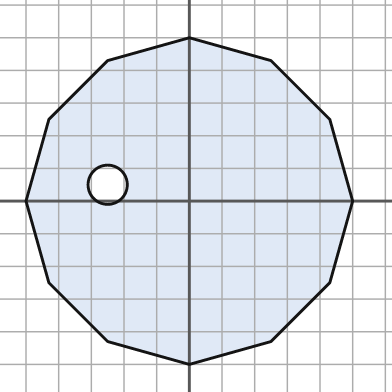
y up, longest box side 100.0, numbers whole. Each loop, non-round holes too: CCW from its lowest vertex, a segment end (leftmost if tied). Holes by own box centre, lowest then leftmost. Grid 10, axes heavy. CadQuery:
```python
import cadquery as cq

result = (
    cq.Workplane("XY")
    .moveTo(0.0, -50.0)
    .lineTo(25.0, -43.0)
    .lineTo(43.0, -25.0)
    .lineTo(50.0, 0.0)
    .lineTo(43.0, 25.0)
    .lineTo(25.0, 43.0)
    .lineTo(0.0, 50.0)
    .lineTo(-25.0, 43.0)
    .lineTo(-43.0, 25.0)
    .lineTo(-50.0, 0.0)
    .lineTo(-43.0, -25.0)
    .lineTo(-25.0, -43.0)
    .close()
    .moveTo(-25.0, 5.0)
    .circle(6.0)
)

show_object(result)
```